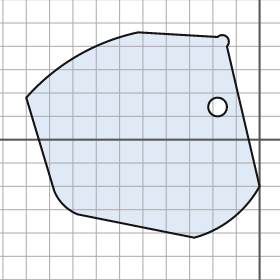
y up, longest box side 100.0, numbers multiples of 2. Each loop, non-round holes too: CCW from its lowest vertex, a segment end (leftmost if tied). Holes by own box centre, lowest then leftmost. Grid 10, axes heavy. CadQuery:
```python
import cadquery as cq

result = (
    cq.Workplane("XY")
    .moveTo(-28.0, -42.0)
    .threePointArc((-12.0, -34.0), (0.0, -20.0))
    .lineTo(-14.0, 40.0)
    .threePointArc((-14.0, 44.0), (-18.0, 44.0))
    .lineTo(-52.0, 46.0)
    .threePointArc((-78.0, 36.0), (-100.0, 18.0))
    .lineTo(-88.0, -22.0)
    .threePointArc((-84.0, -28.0), (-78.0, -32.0))
    .close()
    .moveTo(-18.0, 14.0)
    .circle(4.0)
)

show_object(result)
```